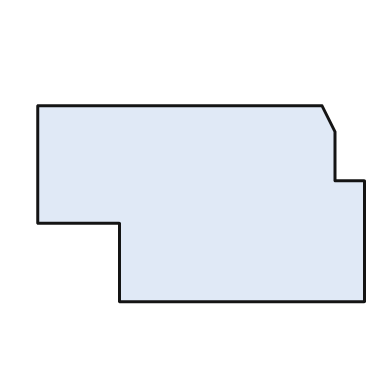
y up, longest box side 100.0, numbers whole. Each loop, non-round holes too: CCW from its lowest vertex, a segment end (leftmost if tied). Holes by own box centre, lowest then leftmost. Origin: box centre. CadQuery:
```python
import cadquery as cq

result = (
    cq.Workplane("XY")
    .moveTo(-25.0, -30.0)
    .lineTo(50.0, -30.0)
    .lineTo(50.0, 7.0)
    .lineTo(41.0, 7.0)
    .lineTo(41.0, 22.0)
    .lineTo(37.0, 30.0)
    .lineTo(-50.0, 30.0)
    .lineTo(-50.0, -6.0)
    .lineTo(-25.0, -6.0)
    .close()
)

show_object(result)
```